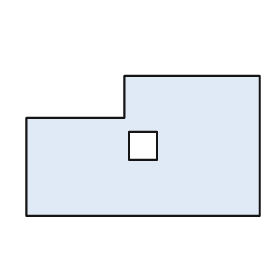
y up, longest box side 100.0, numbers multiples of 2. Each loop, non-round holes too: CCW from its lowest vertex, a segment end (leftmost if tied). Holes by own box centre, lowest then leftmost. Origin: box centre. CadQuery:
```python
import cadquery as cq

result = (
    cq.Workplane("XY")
    .moveTo(-50.0, -30.0)
    .lineTo(50.0, -30.0)
    .lineTo(50.0, 30.0)
    .lineTo(-8.0, 30.0)
    .lineTo(-8.0, 12.0)
    .lineTo(-50.0, 12.0)
    .close()
    .moveTo(-6.0, -6.0)
    .lineTo(6.0, -6.0)
    .lineTo(6.0, 6.0)
    .lineTo(-6.0, 6.0)
    .close()
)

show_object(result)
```